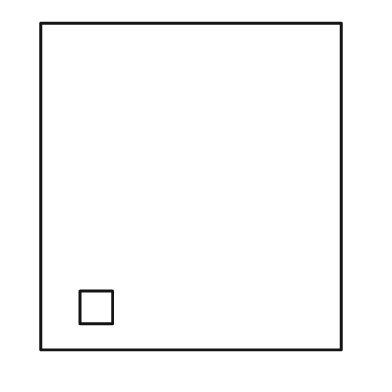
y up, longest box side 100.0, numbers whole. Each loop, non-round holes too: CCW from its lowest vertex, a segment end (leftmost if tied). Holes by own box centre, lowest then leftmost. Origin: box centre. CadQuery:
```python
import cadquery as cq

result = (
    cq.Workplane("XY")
    .moveTo(-46.0, -50.0)
    .lineTo(46.0, -50.0)
    .lineTo(46.0, 50.0)
    .lineTo(-46.0, 50.0)
    .close()
    .moveTo(-34.0, -42.0)
    .lineTo(-24.0, -42.0)
    .lineTo(-24.0, -32.0)
    .lineTo(-34.0, -32.0)
    .close()
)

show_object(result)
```